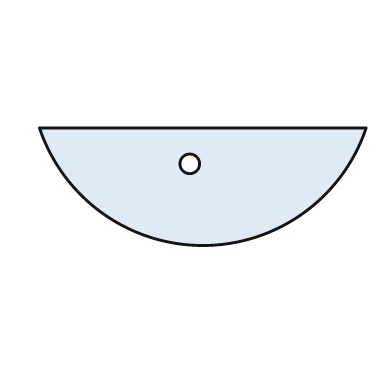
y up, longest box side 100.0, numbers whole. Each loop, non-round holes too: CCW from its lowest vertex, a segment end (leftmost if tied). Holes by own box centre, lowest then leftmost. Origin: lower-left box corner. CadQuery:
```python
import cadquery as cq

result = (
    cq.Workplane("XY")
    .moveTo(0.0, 36.0)
    .threePointArc((50.0, 0.0), (100.0, 36.0))
    .close()
    .moveTo(46.0, 25.0)
    .circle(3.0)
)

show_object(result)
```